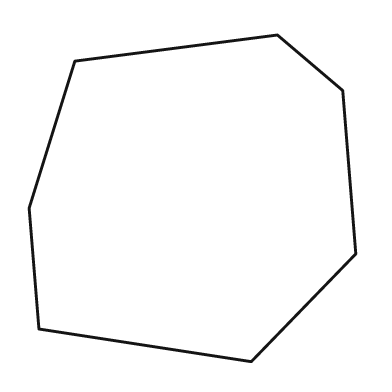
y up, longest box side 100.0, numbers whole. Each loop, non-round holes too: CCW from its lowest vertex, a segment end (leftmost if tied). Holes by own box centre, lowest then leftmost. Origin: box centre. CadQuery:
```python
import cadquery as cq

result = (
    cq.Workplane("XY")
    .moveTo(18.0, -50.0)
    .lineTo(50.0, -17.0)
    .lineTo(46.0, 33.0)
    .lineTo(26.0, 50.0)
    .lineTo(-36.0, 42.0)
    .lineTo(-50.0, -3.0)
    .lineTo(-47.0, -40.0)
    .close()
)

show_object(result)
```